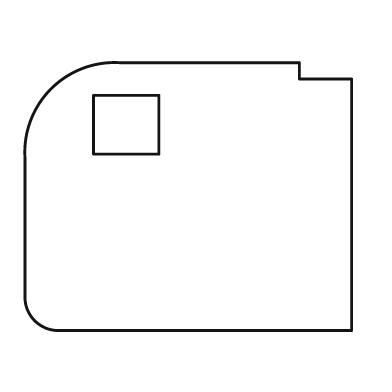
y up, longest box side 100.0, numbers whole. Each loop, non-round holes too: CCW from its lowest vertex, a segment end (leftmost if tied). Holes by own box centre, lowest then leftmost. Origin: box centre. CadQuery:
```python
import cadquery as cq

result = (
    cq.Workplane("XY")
    .moveTo(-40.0, -41.0)
    .lineTo(50.0, -41.0)
    .lineTo(50.0, 36.0)
    .lineTo(34.0, 36.0)
    .lineTo(34.0, 41.0)
    .lineTo(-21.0, 41.0)
    .threePointArc((-42.0, 33.0), (-50.0, 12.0))
    .lineTo(-50.0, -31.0)
    .threePointArc((-47.0, -38.0), (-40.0, -41.0))
    .close()
    .moveTo(-29.0, 13.0)
    .lineTo(-9.0, 13.0)
    .lineTo(-9.0, 31.0)
    .lineTo(-29.0, 31.0)
    .close()
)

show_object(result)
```